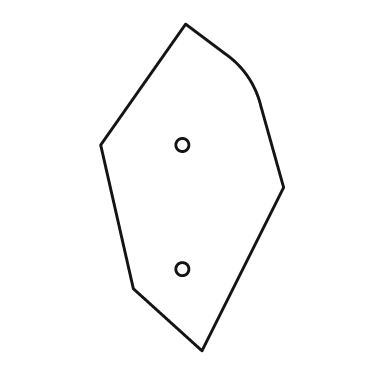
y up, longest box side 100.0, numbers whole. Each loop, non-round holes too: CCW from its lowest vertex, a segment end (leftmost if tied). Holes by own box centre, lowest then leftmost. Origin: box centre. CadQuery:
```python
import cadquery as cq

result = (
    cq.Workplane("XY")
    .moveTo(3.0, -50.0)
    .lineTo(28.0, 0.0)
    .lineTo(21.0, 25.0)
    .threePointArc((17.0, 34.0), (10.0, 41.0))
    .lineTo(-2.0, 50.0)
    .lineTo(-28.0, 13.0)
    .lineTo(-18.0, -31.0)
    .close()
    .moveTo(-3.0, -25.0)
    .circle(2.0)
    .moveTo(-3.0, 13.0)
    .circle(2.0)
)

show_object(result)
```